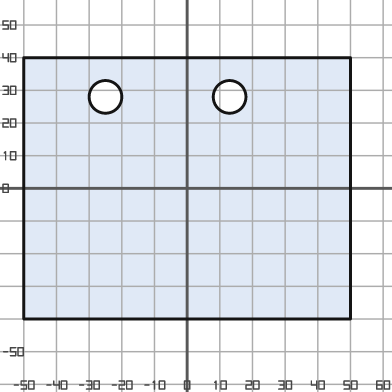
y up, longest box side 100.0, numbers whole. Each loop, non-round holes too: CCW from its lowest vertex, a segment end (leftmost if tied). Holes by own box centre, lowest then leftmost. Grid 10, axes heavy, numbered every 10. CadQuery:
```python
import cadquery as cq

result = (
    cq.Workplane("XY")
    .moveTo(-50.0, -40.0)
    .lineTo(50.0, -40.0)
    .lineTo(50.0, 40.0)
    .lineTo(-50.0, 40.0)
    .close()
    .moveTo(-25.0, 28.0)
    .circle(5.0)
    .moveTo(13.0, 28.0)
    .circle(5.0)
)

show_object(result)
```